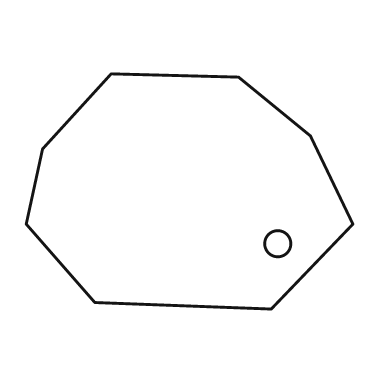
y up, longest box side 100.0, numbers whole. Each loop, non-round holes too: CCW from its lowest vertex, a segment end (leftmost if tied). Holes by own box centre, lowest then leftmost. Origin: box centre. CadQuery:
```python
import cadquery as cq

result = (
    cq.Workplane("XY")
    .moveTo(25.0, -36.0)
    .lineTo(50.0, -10.0)
    .lineTo(37.0, 17.0)
    .lineTo(15.0, 35.0)
    .lineTo(-24.0, 36.0)
    .lineTo(-45.0, 13.0)
    .lineTo(-50.0, -10.0)
    .lineTo(-29.0, -34.0)
    .close()
    .moveTo(27.0, -16.0)
    .circle(4.0)
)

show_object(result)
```